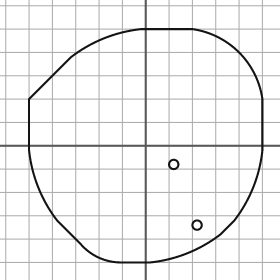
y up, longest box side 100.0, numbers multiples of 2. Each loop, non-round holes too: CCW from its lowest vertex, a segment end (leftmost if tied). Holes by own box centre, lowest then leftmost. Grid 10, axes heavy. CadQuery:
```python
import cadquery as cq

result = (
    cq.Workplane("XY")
    .moveTo(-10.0, -50.0)
    .lineTo(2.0, -50.0)
    .threePointArc((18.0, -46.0), (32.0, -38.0))
    .lineTo(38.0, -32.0)
    .threePointArc((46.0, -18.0), (50.0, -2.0))
    .lineTo(50.0, 20.0)
    .threePointArc((40.0, 40.0), (20.0, 50.0))
    .lineTo(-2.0, 50.0)
    .threePointArc((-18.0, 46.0), (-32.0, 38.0))
    .lineTo(-50.0, 20.0)
    .lineTo(-50.0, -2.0)
    .threePointArc((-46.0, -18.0), (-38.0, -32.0))
    .lineTo(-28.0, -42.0)
    .threePointArc((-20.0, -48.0), (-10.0, -50.0))
    .close()
    .moveTo(22.0, -34.0)
    .circle(2.0)
    .moveTo(12.0, -8.0)
    .circle(2.0)
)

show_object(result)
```